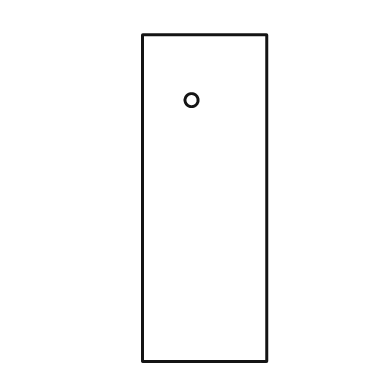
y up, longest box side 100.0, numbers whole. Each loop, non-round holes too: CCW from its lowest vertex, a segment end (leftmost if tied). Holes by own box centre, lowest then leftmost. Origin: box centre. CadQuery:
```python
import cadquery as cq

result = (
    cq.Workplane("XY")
    .moveTo(-19.0, -50.0)
    .lineTo(19.0, -50.0)
    .lineTo(19.0, 50.0)
    .lineTo(-19.0, 50.0)
    .close()
    .moveTo(-4.0, 30.0)
    .circle(2.0)
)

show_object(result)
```